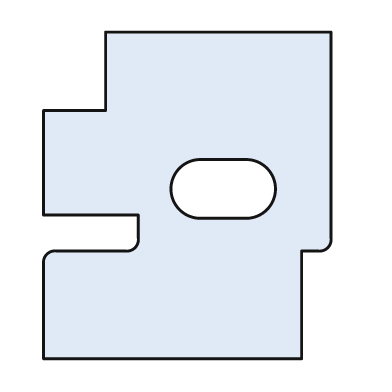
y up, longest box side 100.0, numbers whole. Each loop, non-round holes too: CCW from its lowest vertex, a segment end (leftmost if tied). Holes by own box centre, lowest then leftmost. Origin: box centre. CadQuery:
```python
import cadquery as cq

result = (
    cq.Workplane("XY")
    .moveTo(-44.0, -50.0)
    .lineTo(35.0, -50.0)
    .lineTo(35.0, -17.0)
    .lineTo(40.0, -17.0)
    .threePointArc((43.0, -16.0), (44.0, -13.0))
    .lineTo(44.0, 50.0)
    .lineTo(-25.0, 50.0)
    .lineTo(-25.0, 26.0)
    .lineTo(-44.0, 26.0)
    .lineTo(-44.0, -6.0)
    .lineTo(-15.0, -6.0)
    .lineTo(-15.0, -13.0)
    .threePointArc((-16.0, -16.0), (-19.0, -17.0))
    .lineTo(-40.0, -17.0)
    .threePointArc((-43.0, -18.0), (-44.0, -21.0))
    .close()
    .moveTo(4.0, -7.0)
    .lineTo(18.0, -7.0)
    .threePointArc((27.0, 2.0), (18.0, 11.0))
    .lineTo(4.0, 11.0)
    .threePointArc((-5.0, 2.0), (4.0, -7.0))
    .close()
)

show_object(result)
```